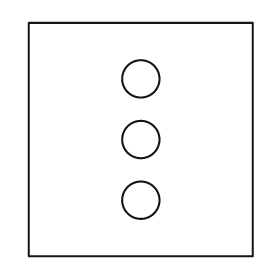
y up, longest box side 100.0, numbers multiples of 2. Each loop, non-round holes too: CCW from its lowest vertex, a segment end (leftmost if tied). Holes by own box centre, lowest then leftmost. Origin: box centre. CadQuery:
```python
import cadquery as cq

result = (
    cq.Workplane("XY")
    .moveTo(-48.0, -50.0)
    .lineTo(48.0, -50.0)
    .lineTo(48.0, 50.0)
    .lineTo(-48.0, 50.0)
    .close()
    .moveTo(0.0, -26.0)
    .circle(8.0)
    .moveTo(0.0, 0.0)
    .circle(8.0)
    .moveTo(0.0, 26.0)
    .circle(8.0)
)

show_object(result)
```